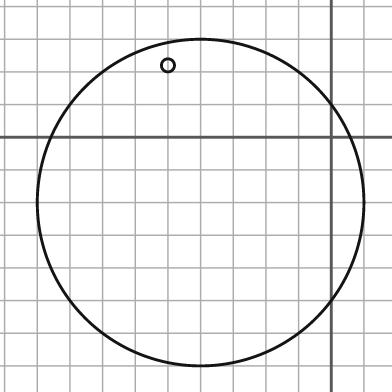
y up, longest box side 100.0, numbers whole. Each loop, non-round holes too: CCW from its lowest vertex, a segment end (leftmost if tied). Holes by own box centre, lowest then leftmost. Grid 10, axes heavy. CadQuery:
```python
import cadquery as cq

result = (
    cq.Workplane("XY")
    .moveTo(-40.0, -20.0)
    .circle(50.0)
    .moveTo(-50.0, 22.0)
    .circle(2.0)
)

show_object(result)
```